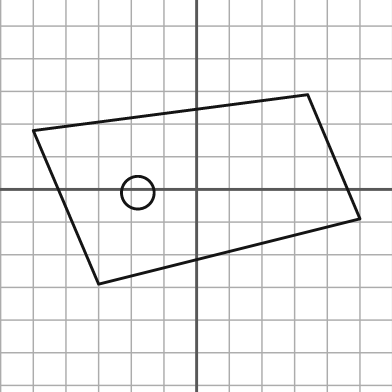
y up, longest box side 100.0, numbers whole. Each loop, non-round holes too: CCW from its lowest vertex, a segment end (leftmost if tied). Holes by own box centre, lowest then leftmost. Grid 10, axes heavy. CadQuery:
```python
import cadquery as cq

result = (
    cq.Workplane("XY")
    .moveTo(-30.0, -29.0)
    .lineTo(50.0, -9.0)
    .lineTo(34.0, 29.0)
    .lineTo(-50.0, 18.0)
    .close()
    .moveTo(-18.0, -1.0)
    .circle(5.0)
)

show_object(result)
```